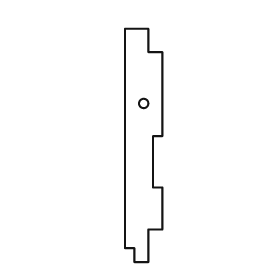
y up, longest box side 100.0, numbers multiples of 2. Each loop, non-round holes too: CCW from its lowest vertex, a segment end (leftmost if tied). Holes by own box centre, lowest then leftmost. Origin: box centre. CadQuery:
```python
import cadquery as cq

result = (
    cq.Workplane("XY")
    .moveTo(-4.0, -50.0)
    .lineTo(2.0, -50.0)
    .lineTo(2.0, -36.0)
    .lineTo(8.0, -36.0)
    .lineTo(8.0, -18.0)
    .lineTo(4.0, -18.0)
    .lineTo(4.0, 4.0)
    .lineTo(8.0, 4.0)
    .lineTo(8.0, 40.0)
    .lineTo(2.0, 40.0)
    .lineTo(2.0, 50.0)
    .lineTo(-8.0, 50.0)
    .lineTo(-8.0, -44.0)
    .lineTo(-4.0, -44.0)
    .close()
    .moveTo(0.0, 18.0)
    .circle(2.0)
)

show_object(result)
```